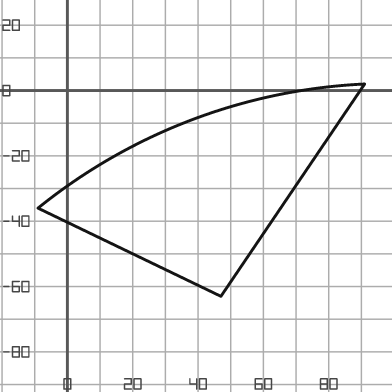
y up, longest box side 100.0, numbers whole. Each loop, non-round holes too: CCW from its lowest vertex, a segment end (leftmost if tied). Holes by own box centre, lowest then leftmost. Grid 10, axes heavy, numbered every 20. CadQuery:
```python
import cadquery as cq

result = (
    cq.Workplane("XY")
    .moveTo(47.0, -63.0)
    .lineTo(91.0, 2.0)
    .threePointArc((38.0, -9.0), (-9.0, -36.0))
    .close()
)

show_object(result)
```